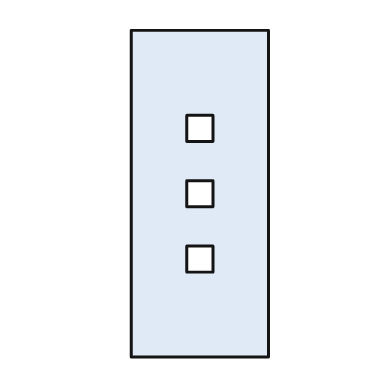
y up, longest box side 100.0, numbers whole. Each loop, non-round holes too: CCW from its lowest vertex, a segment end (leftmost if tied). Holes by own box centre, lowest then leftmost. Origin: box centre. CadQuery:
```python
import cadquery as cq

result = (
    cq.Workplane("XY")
    .moveTo(-21.0, -50.0)
    .lineTo(21.0, -50.0)
    .lineTo(21.0, 50.0)
    .lineTo(-21.0, 50.0)
    .close()
    .moveTo(-4.0, -24.0)
    .lineTo(4.0, -24.0)
    .lineTo(4.0, -16.0)
    .lineTo(-4.0, -16.0)
    .close()
    .moveTo(-4.0, -4.0)
    .lineTo(4.0, -4.0)
    .lineTo(4.0, 4.0)
    .lineTo(-4.0, 4.0)
    .close()
    .moveTo(-4.0, 16.0)
    .lineTo(4.0, 16.0)
    .lineTo(4.0, 24.0)
    .lineTo(-4.0, 24.0)
    .close()
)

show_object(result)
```